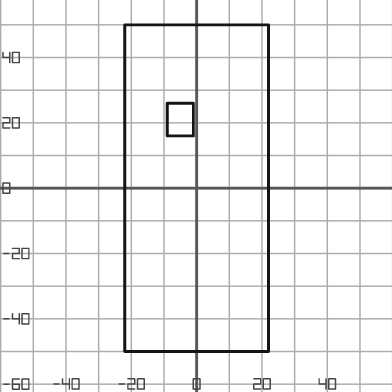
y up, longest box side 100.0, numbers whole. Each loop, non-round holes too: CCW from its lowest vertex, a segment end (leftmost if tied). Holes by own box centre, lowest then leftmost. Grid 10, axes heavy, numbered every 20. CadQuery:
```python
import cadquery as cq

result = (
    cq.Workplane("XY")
    .moveTo(-22.0, -50.0)
    .lineTo(22.0, -50.0)
    .lineTo(22.0, 50.0)
    .lineTo(-22.0, 50.0)
    .close()
    .moveTo(-9.0, 16.0)
    .lineTo(-1.0, 16.0)
    .lineTo(-1.0, 26.0)
    .lineTo(-9.0, 26.0)
    .close()
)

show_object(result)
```